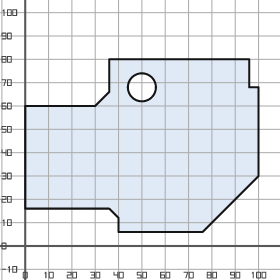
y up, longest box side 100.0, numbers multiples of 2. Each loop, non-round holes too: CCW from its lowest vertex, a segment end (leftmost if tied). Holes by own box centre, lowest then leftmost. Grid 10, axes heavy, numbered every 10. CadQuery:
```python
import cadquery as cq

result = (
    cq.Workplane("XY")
    .moveTo(40.0, 6.0)
    .lineTo(76.0, 6.0)
    .lineTo(100.0, 30.0)
    .lineTo(100.0, 68.0)
    .lineTo(96.0, 68.0)
    .lineTo(96.0, 80.0)
    .lineTo(36.0, 80.0)
    .lineTo(36.0, 66.0)
    .lineTo(30.0, 60.0)
    .lineTo(0.0, 60.0)
    .lineTo(0.0, 16.0)
    .lineTo(36.0, 16.0)
    .lineTo(40.0, 12.0)
    .close()
    .moveTo(50.0, 68.0)
    .circle(6.0)
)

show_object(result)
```